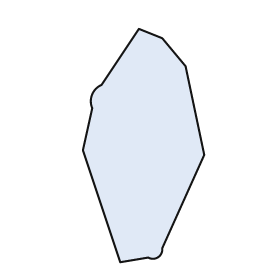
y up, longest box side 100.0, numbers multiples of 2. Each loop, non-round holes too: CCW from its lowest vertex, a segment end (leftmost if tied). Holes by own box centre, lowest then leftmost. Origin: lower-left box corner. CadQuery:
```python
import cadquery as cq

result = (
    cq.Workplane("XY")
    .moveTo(16.0, 0.0)
    .lineTo(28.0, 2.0)
    .threePointArc((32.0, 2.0), (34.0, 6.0))
    .lineTo(52.0, 46.0)
    .lineTo(44.0, 84.0)
    .lineTo(34.0, 96.0)
    .lineTo(24.0, 100.0)
    .lineTo(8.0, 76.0)
    .threePointArc((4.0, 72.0), (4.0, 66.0))
    .lineTo(0.0, 48.0)
    .close()
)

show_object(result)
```